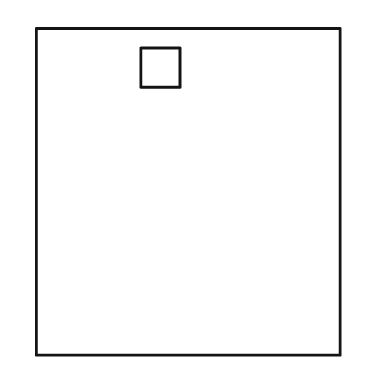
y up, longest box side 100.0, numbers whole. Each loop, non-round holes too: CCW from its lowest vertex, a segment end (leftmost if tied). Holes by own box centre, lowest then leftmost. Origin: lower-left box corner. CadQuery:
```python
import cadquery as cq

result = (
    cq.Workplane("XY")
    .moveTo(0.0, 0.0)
    .lineTo(93.0, 0.0)
    .lineTo(93.0, 100.0)
    .lineTo(0.0, 100.0)
    .close()
    .moveTo(32.0, 82.0)
    .lineTo(44.0, 82.0)
    .lineTo(44.0, 94.0)
    .lineTo(32.0, 94.0)
    .close()
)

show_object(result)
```